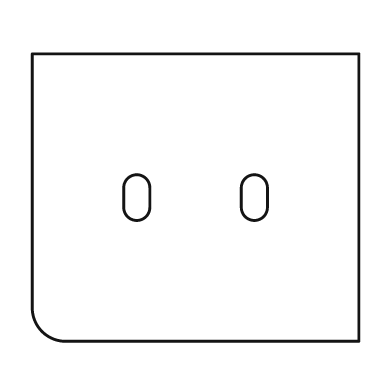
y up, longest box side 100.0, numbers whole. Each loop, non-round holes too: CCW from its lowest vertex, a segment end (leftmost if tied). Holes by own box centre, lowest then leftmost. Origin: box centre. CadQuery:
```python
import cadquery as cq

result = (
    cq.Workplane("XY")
    .moveTo(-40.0, -44.0)
    .lineTo(50.0, -44.0)
    .lineTo(50.0, 44.0)
    .lineTo(-50.0, 44.0)
    .lineTo(-50.0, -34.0)
    .threePointArc((-47.0, -41.0), (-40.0, -44.0))
    .close()
    .moveTo(-22.0, -3.0)
    .threePointArc((-18.0, -7.0), (-14.0, -3.0))
    .lineTo(-14.0, 3.0)
    .threePointArc((-18.0, 7.0), (-22.0, 3.0))
    .close()
    .moveTo(14.0, -3.0)
    .threePointArc((18.0, -7.0), (22.0, -3.0))
    .lineTo(22.0, 3.0)
    .threePointArc((18.0, 7.0), (14.0, 3.0))
    .close()
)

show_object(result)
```